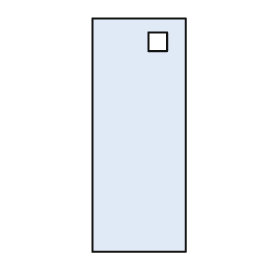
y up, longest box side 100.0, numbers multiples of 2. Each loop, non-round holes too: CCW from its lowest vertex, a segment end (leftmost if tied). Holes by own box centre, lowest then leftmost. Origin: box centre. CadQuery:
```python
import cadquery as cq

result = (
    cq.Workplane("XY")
    .moveTo(-20.0, -50.0)
    .lineTo(20.0, -50.0)
    .lineTo(20.0, 50.0)
    .lineTo(-20.0, 50.0)
    .close()
    .moveTo(4.0, 36.0)
    .lineTo(12.0, 36.0)
    .lineTo(12.0, 44.0)
    .lineTo(4.0, 44.0)
    .close()
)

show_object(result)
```